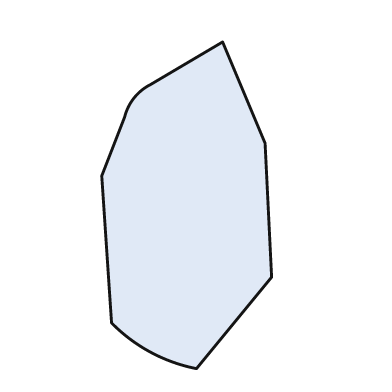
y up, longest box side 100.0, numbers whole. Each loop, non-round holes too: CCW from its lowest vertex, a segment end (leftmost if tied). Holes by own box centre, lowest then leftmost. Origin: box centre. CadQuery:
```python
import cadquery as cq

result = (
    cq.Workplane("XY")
    .moveTo(3.0, -50.0)
    .lineTo(26.0, -22.0)
    .lineTo(24.0, 19.0)
    .lineTo(11.0, 50.0)
    .lineTo(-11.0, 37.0)
    .threePointArc((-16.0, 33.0), (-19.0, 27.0))
    .lineTo(-26.0, 9.0)
    .lineTo(-23.0, -36.0)
    .threePointArc((-11.0, -45.0), (3.0, -50.0))
    .close()
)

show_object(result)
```